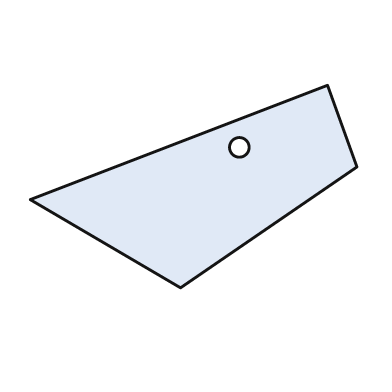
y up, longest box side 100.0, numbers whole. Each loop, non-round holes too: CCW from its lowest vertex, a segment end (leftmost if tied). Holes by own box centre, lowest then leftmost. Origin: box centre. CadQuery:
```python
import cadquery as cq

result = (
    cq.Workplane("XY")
    .moveTo(-4.0, -31.0)
    .lineTo(50.0, 6.0)
    .lineTo(41.0, 31.0)
    .lineTo(-50.0, -4.0)
    .close()
    .moveTo(14.0, 12.0)
    .circle(3.0)
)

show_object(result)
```